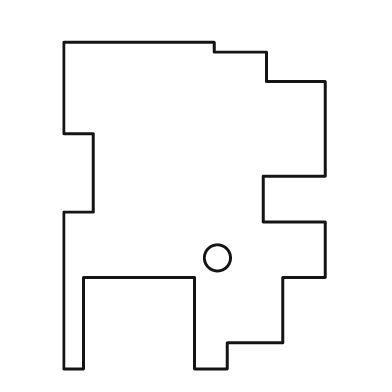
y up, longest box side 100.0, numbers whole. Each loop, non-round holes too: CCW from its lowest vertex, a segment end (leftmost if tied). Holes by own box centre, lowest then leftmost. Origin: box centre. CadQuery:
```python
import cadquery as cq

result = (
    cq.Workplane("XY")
    .moveTo(-40.0, -50.0)
    .lineTo(-34.0, -50.0)
    .lineTo(-34.0, -22.0)
    .lineTo(0.0, -22.0)
    .lineTo(0.0, -50.0)
    .lineTo(10.0, -50.0)
    .lineTo(10.0, -42.0)
    .lineTo(27.0, -42.0)
    .lineTo(27.0, -22.0)
    .lineTo(40.0, -22.0)
    .lineTo(40.0, -5.0)
    .lineTo(21.0, -5.0)
    .lineTo(21.0, 9.0)
    .lineTo(40.0, 9.0)
    .lineTo(40.0, 38.0)
    .lineTo(22.0, 38.0)
    .lineTo(22.0, 47.0)
    .lineTo(6.0, 47.0)
    .lineTo(6.0, 50.0)
    .lineTo(-40.0, 50.0)
    .lineTo(-40.0, 22.0)
    .lineTo(-31.0, 22.0)
    .lineTo(-31.0, -2.0)
    .lineTo(-40.0, -2.0)
    .close()
    .moveTo(7.0, -16.0)
    .circle(4.0)
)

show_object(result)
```